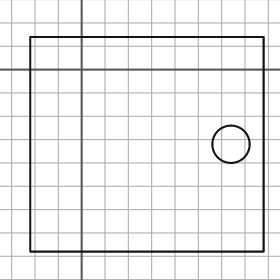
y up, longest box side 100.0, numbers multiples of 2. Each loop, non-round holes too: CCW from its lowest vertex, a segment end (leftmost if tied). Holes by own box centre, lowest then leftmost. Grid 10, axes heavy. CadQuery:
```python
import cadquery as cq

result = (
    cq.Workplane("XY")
    .moveTo(-22.0, -78.0)
    .lineTo(78.0, -78.0)
    .lineTo(78.0, 14.0)
    .lineTo(-22.0, 14.0)
    .close()
    .moveTo(64.0, -32.0)
    .circle(8.0)
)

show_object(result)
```